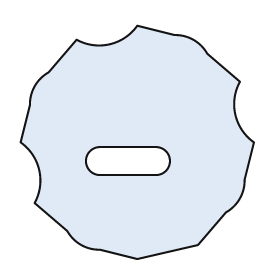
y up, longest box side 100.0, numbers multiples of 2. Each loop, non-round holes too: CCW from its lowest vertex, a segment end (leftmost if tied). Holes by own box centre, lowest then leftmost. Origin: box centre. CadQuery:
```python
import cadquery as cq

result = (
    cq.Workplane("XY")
    .moveTo(0.0, -50.0)
    .lineTo(26.0, -44.0)
    .lineTo(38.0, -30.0)
    .threePointArc((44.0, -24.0), (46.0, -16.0))
    .lineTo(50.0, 0.0)
    .threePointArc((42.0, 12.0), (44.0, 26.0))
    .lineTo(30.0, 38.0)
    .threePointArc((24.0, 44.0), (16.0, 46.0))
    .lineTo(0.0, 50.0)
    .threePointArc((-12.0, 42.0), (-26.0, 44.0))
    .lineTo(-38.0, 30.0)
    .threePointArc((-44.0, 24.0), (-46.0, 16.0))
    .lineTo(-50.0, 0.0)
    .threePointArc((-42.0, -12.0), (-44.0, -26.0))
    .lineTo(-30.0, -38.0)
    .threePointArc((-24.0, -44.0), (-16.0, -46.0))
    .close()
    .moveTo(-16.0, -14.0)
    .lineTo(8.0, -14.0)
    .threePointArc((14.0, -8.0), (8.0, -2.0))
    .lineTo(-16.0, -2.0)
    .threePointArc((-22.0, -8.0), (-16.0, -14.0))
    .close()
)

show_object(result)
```